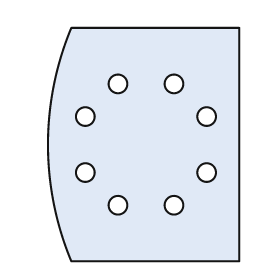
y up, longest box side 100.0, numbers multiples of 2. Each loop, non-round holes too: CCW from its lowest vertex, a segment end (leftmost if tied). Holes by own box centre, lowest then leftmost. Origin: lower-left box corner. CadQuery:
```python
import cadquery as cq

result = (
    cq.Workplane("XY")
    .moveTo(10.0, 0.0)
    .lineTo(82.0, 0.0)
    .lineTo(82.0, 100.0)
    .lineTo(10.0, 100.0)
    .threePointArc((0.0, 50.0), (10.0, 0.0))
    .close()
    .moveTo(30.0, 24.0)
    .circle(4.0)
    .moveTo(54.0, 24.0)
    .circle(4.0)
    .moveTo(16.0, 38.0)
    .circle(4.0)
    .moveTo(68.0, 38.0)
    .circle(4.0)
    .moveTo(16.0, 62.0)
    .circle(4.0)
    .moveTo(68.0, 62.0)
    .circle(4.0)
    .moveTo(30.0, 76.0)
    .circle(4.0)
    .moveTo(54.0, 76.0)
    .circle(4.0)
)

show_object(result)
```